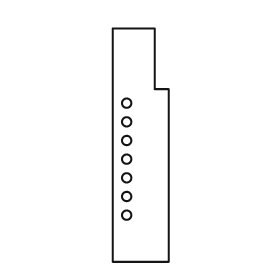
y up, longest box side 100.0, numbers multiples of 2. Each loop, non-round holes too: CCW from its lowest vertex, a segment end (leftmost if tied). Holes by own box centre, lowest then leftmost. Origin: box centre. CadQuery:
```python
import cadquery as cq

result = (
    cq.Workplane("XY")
    .moveTo(-12.0, -50.0)
    .lineTo(12.0, -50.0)
    .lineTo(12.0, 24.0)
    .lineTo(6.0, 24.0)
    .lineTo(6.0, 50.0)
    .lineTo(-12.0, 50.0)
    .close()
    .moveTo(-6.0, -30.0)
    .circle(2.0)
    .moveTo(-6.0, -22.0)
    .circle(2.0)
    .moveTo(-6.0, -14.0)
    .circle(2.0)
    .moveTo(-6.0, -6.0)
    .circle(2.0)
    .moveTo(-6.0, 2.0)
    .circle(2.0)
    .moveTo(-6.0, 10.0)
    .circle(2.0)
    .moveTo(-6.0, 18.0)
    .circle(2.0)
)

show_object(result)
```